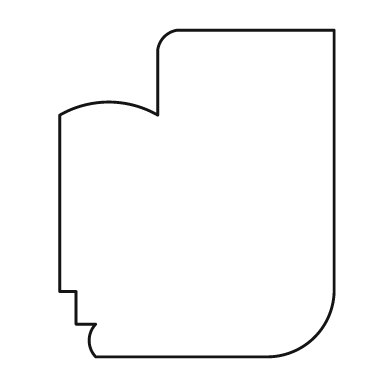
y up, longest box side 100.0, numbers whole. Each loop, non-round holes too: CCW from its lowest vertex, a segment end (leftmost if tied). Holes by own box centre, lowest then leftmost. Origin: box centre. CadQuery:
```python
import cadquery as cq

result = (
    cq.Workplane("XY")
    .moveTo(-31.0, -50.0)
    .lineTo(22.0, -50.0)
    .threePointArc((36.0, -44.0), (42.0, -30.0))
    .lineTo(42.0, 50.0)
    .lineTo(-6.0, 50.0)
    .threePointArc((-10.0, 48.0), (-12.0, 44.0))
    .lineTo(-12.0, 24.0)
    .threePointArc((-27.0, 28.0), (-42.0, 24.0))
    .lineTo(-42.0, -30.0)
    .lineTo(-37.0, -30.0)
    .lineTo(-37.0, -40.0)
    .lineTo(-31.0, -40.0)
    .threePointArc((-33.0, -45.0), (-31.0, -50.0))
    .close()
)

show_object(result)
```